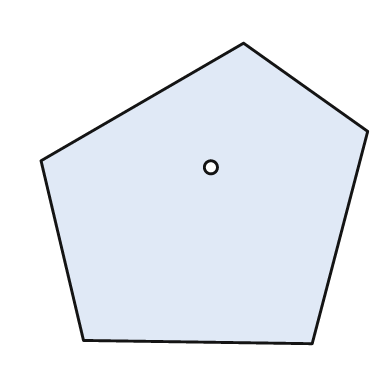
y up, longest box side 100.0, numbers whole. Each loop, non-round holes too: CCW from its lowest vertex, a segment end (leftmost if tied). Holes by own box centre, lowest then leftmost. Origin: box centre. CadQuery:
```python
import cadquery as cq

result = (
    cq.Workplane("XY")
    .moveTo(33.0, -46.0)
    .lineTo(50.0, 19.0)
    .lineTo(12.0, 46.0)
    .lineTo(-50.0, 10.0)
    .lineTo(-37.0, -45.0)
    .close()
    .moveTo(2.0, 8.0)
    .circle(2.0)
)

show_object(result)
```